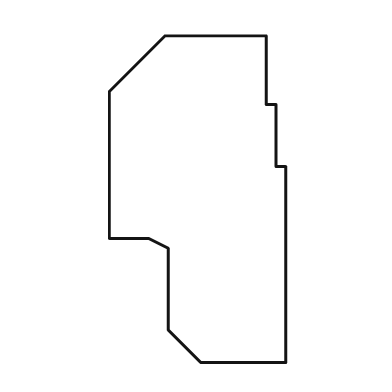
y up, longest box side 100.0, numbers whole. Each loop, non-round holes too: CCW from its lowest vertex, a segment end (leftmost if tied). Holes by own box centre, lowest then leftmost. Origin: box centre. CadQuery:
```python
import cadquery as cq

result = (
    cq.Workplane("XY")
    .moveTo(1.0, -50.0)
    .lineTo(27.0, -50.0)
    .lineTo(27.0, 10.0)
    .lineTo(24.0, 10.0)
    .lineTo(24.0, 29.0)
    .lineTo(21.0, 29.0)
    .lineTo(21.0, 50.0)
    .lineTo(-10.0, 50.0)
    .lineTo(-27.0, 33.0)
    .lineTo(-27.0, -12.0)
    .lineTo(-15.0, -12.0)
    .lineTo(-9.0, -15.0)
    .lineTo(-9.0, -40.0)
    .close()
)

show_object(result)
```